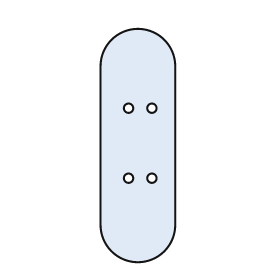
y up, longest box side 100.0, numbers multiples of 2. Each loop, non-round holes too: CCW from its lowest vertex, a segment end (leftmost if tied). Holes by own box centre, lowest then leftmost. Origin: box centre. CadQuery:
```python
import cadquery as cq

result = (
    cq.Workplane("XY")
    .moveTo(-16.0, -34.0)
    .threePointArc((0.0, -50.0), (16.0, -34.0))
    .lineTo(16.0, 34.0)
    .threePointArc((0.0, 50.0), (-16.0, 34.0))
    .close()
    .moveTo(-4.0, -14.0)
    .circle(2.0)
    .moveTo(6.0, -14.0)
    .circle(2.0)
    .moveTo(-4.0, 16.0)
    .circle(2.0)
    .moveTo(6.0, 16.0)
    .circle(2.0)
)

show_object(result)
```